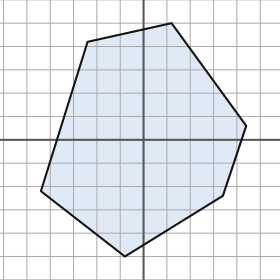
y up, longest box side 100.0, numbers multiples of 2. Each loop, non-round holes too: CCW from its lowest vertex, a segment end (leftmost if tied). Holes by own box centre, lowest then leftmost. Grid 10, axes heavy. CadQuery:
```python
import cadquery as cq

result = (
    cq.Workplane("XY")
    .moveTo(-8.0, -50.0)
    .lineTo(34.0, -24.0)
    .lineTo(44.0, 6.0)
    .lineTo(12.0, 50.0)
    .lineTo(-24.0, 42.0)
    .lineTo(-44.0, -22.0)
    .close()
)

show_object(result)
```